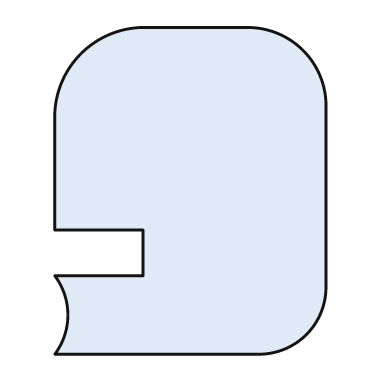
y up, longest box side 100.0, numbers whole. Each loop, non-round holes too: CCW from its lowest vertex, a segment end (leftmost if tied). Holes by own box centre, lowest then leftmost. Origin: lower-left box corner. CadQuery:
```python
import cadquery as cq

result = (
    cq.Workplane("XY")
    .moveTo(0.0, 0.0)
    .lineTo(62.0, 0.0)
    .threePointArc((77.0, 6.0), (83.0, 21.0))
    .lineTo(83.0, 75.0)
    .threePointArc((76.0, 93.0), (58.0, 100.0))
    .lineTo(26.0, 100.0)
    .threePointArc((8.0, 92.0), (0.0, 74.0))
    .lineTo(0.0, 38.0)
    .lineTo(27.0, 38.0)
    .lineTo(27.0, 24.0)
    .lineTo(0.0, 24.0)
    .threePointArc((4.0, 12.0), (0.0, 0.0))
    .close()
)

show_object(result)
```